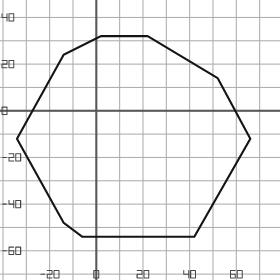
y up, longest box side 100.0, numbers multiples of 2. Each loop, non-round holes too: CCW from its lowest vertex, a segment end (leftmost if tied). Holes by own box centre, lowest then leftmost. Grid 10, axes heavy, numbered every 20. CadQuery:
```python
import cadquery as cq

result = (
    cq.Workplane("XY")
    .moveTo(-6.0, -54.0)
    .lineTo(42.0, -54.0)
    .lineTo(66.0, -12.0)
    .lineTo(52.0, 14.0)
    .lineTo(22.0, 32.0)
    .lineTo(2.0, 32.0)
    .lineTo(-14.0, 24.0)
    .lineTo(-34.0, -12.0)
    .lineTo(-14.0, -48.0)
    .close()
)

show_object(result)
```